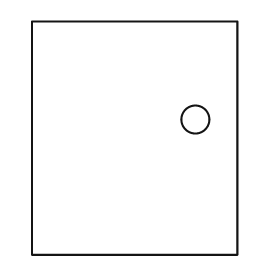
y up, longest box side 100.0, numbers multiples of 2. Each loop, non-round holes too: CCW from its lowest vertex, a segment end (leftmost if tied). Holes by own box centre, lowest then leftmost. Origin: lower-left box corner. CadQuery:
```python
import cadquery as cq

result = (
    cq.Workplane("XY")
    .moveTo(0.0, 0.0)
    .lineTo(88.0, 0.0)
    .lineTo(88.0, 100.0)
    .lineTo(0.0, 100.0)
    .close()
    .moveTo(70.0, 58.0)
    .circle(6.0)
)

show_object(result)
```